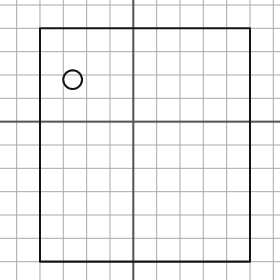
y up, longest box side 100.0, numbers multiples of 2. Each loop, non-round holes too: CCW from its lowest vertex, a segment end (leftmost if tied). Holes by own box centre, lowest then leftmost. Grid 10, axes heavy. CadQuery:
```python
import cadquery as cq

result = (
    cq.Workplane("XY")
    .moveTo(-40.0, -60.0)
    .lineTo(50.0, -60.0)
    .lineTo(50.0, 40.0)
    .lineTo(-40.0, 40.0)
    .close()
    .moveTo(-26.0, 18.0)
    .circle(4.0)
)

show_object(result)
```